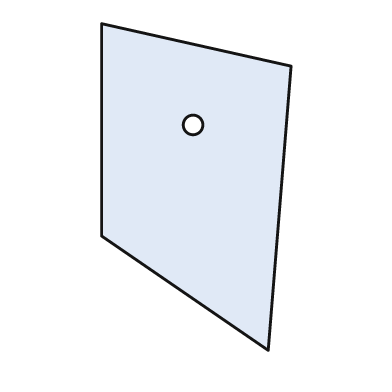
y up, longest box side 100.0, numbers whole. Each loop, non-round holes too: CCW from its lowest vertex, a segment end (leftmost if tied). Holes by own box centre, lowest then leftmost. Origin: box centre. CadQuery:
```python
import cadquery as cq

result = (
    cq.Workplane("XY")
    .moveTo(22.0, -50.0)
    .lineTo(29.0, 37.0)
    .lineTo(-29.0, 50.0)
    .lineTo(-29.0, -15.0)
    .close()
    .moveTo(-1.0, 19.0)
    .circle(3.0)
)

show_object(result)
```